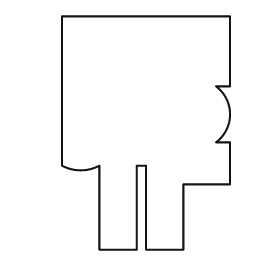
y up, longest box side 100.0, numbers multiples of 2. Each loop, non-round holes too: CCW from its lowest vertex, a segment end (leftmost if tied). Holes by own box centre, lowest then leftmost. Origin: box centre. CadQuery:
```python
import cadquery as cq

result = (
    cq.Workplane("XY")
    .moveTo(-20.0, -50.0)
    .lineTo(-4.0, -50.0)
    .lineTo(-4.0, -14.0)
    .lineTo(0.0, -14.0)
    .lineTo(0.0, -50.0)
    .lineTo(16.0, -50.0)
    .lineTo(16.0, -22.0)
    .lineTo(36.0, -22.0)
    .lineTo(36.0, -4.0)
    .lineTo(30.0, -4.0)
    .threePointArc((36.0, 8.0), (30.0, 20.0))
    .lineTo(36.0, 20.0)
    .lineTo(36.0, 50.0)
    .lineTo(-36.0, 50.0)
    .lineTo(-36.0, -14.0)
    .threePointArc((-28.0, -16.0), (-20.0, -14.0))
    .close()
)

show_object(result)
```